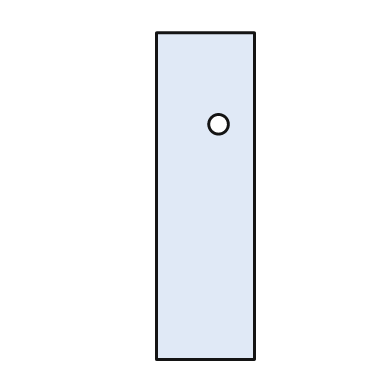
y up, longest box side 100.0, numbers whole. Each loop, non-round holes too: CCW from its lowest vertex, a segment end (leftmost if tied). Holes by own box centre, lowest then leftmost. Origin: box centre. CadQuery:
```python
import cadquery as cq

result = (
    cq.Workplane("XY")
    .moveTo(-15.0, -50.0)
    .lineTo(15.0, -50.0)
    .lineTo(15.0, 50.0)
    .lineTo(-15.0, 50.0)
    .close()
    .moveTo(4.0, 22.0)
    .circle(3.0)
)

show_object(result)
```